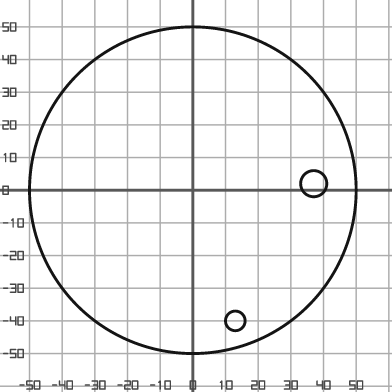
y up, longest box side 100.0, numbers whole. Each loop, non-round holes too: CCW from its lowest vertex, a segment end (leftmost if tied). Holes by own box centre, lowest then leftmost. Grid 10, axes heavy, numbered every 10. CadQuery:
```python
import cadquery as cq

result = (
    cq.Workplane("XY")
    .moveTo(0.0, 0.0)
    .circle(50.0)
    .moveTo(13.0, -40.0)
    .circle(3.0)
    .moveTo(37.0, 2.0)
    .circle(4.0)
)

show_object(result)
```